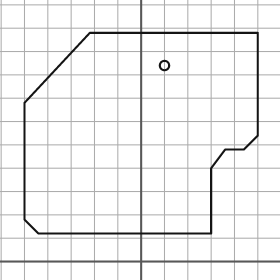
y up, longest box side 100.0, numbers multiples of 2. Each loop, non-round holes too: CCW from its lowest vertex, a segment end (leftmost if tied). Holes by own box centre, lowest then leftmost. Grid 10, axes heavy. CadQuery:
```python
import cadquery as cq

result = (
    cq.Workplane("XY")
    .moveTo(-44.0, 12.0)
    .lineTo(30.0, 12.0)
    .lineTo(30.0, 40.0)
    .lineTo(36.0, 48.0)
    .lineTo(44.0, 48.0)
    .lineTo(50.0, 54.0)
    .lineTo(50.0, 98.0)
    .lineTo(-22.0, 98.0)
    .lineTo(-50.0, 68.0)
    .lineTo(-50.0, 18.0)
    .close()
    .moveTo(10.0, 84.0)
    .circle(2.0)
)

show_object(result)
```